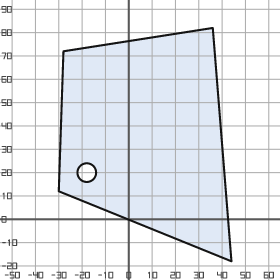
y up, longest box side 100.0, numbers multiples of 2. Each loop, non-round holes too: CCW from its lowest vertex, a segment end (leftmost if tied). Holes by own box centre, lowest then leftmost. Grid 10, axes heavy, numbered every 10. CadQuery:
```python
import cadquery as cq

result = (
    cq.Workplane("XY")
    .moveTo(44.0, -18.0)
    .lineTo(36.0, 82.0)
    .lineTo(-28.0, 72.0)
    .lineTo(-30.0, 12.0)
    .close()
    .moveTo(-18.0, 20.0)
    .circle(4.0)
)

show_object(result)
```